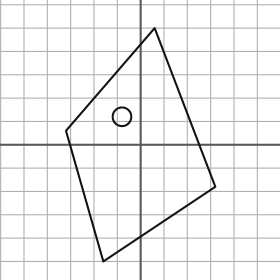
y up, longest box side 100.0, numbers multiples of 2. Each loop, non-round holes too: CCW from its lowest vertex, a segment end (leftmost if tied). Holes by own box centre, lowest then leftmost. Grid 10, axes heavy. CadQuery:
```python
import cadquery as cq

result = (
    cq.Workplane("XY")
    .moveTo(-16.0, -50.0)
    .lineTo(32.0, -18.0)
    .lineTo(6.0, 50.0)
    .lineTo(-32.0, 6.0)
    .close()
    .moveTo(-8.0, 12.0)
    .circle(4.0)
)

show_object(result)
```